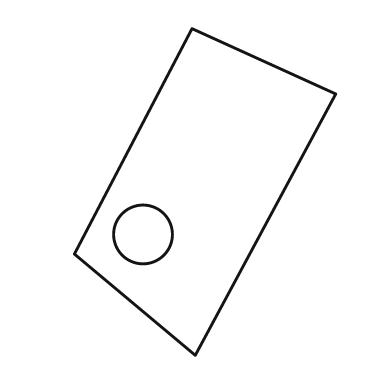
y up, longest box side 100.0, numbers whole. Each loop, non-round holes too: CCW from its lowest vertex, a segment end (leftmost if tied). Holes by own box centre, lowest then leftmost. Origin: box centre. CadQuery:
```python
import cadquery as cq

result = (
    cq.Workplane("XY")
    .moveTo(-3.0, -50.0)
    .lineTo(40.0, 30.0)
    .lineTo(-4.0, 50.0)
    .lineTo(-40.0, -19.0)
    .close()
    .moveTo(-19.0, -13.0)
    .circle(9.0)
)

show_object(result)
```